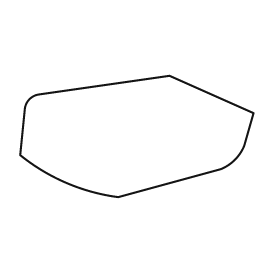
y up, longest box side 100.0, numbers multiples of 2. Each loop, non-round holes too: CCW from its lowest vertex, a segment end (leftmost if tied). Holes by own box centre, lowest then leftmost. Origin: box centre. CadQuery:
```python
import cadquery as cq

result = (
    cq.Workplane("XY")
    .moveTo(-8.0, -26.0)
    .lineTo(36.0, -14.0)
    .threePointArc((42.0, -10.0), (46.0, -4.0))
    .lineTo(50.0, 10.0)
    .lineTo(14.0, 26.0)
    .lineTo(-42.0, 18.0)
    .threePointArc((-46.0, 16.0), (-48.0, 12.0))
    .lineTo(-50.0, -8.0)
    .threePointArc((-30.0, -20.0), (-8.0, -26.0))
    .close()
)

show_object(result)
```